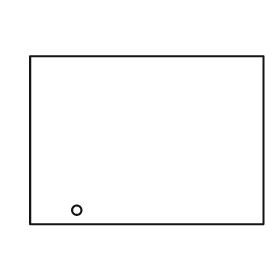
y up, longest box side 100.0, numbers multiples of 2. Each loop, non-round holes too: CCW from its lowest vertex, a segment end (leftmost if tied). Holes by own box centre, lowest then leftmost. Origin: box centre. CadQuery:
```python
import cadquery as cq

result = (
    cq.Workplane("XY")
    .moveTo(-50.0, -36.0)
    .lineTo(50.0, -36.0)
    .lineTo(50.0, 36.0)
    .lineTo(-50.0, 36.0)
    .close()
    .moveTo(-30.0, -30.0)
    .circle(2.0)
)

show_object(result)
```